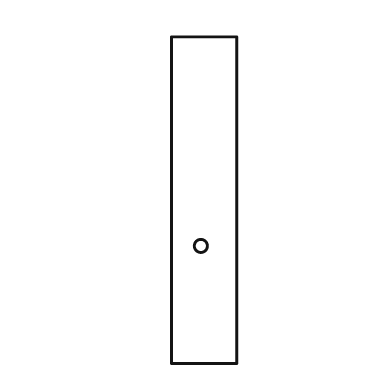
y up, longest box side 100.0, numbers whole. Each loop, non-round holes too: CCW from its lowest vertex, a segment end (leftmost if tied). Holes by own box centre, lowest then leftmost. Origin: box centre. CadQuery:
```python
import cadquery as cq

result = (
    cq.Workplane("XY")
    .moveTo(-10.0, -50.0)
    .lineTo(10.0, -50.0)
    .lineTo(10.0, 50.0)
    .lineTo(-10.0, 50.0)
    .close()
    .moveTo(-1.0, -14.0)
    .circle(2.0)
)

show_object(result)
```